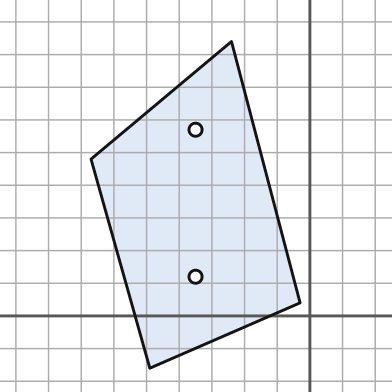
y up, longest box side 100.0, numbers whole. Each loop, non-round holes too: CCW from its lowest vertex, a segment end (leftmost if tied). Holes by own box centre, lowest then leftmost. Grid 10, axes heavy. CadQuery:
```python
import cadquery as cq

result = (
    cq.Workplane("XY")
    .moveTo(-49.0, -16.0)
    .lineTo(-3.0, 4.0)
    .lineTo(-24.0, 84.0)
    .lineTo(-67.0, 48.0)
    .close()
    .moveTo(-35.0, 12.0)
    .circle(2.0)
    .moveTo(-35.0, 57.0)
    .circle(2.0)
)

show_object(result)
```